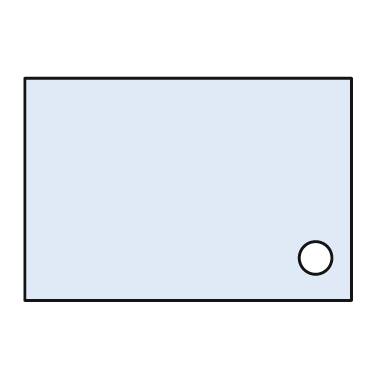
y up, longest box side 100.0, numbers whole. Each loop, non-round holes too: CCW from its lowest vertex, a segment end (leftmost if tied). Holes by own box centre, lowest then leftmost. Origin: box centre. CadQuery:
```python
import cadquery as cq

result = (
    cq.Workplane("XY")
    .moveTo(-50.0, -34.0)
    .lineTo(50.0, -34.0)
    .lineTo(50.0, 34.0)
    .lineTo(-50.0, 34.0)
    .close()
    .moveTo(39.0, -21.0)
    .circle(5.0)
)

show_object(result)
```